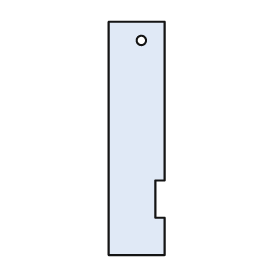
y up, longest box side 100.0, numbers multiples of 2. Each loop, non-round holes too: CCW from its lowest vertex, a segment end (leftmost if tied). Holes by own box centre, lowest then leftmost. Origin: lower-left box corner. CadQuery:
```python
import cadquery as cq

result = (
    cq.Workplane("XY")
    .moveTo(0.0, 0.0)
    .lineTo(24.0, 0.0)
    .lineTo(24.0, 16.0)
    .lineTo(20.0, 16.0)
    .lineTo(20.0, 32.0)
    .lineTo(24.0, 32.0)
    .lineTo(24.0, 100.0)
    .lineTo(0.0, 100.0)
    .close()
    .moveTo(14.0, 92.0)
    .circle(2.0)
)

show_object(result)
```